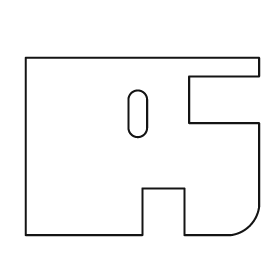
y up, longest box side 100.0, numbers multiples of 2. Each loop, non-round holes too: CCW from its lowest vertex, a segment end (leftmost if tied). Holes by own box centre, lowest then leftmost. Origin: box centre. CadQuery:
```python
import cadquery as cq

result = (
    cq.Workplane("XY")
    .moveTo(-50.0, -38.0)
    .lineTo(0.0, -38.0)
    .lineTo(0.0, -18.0)
    .lineTo(18.0, -18.0)
    .lineTo(18.0, -38.0)
    .lineTo(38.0, -38.0)
    .threePointArc((46.0, -34.0), (50.0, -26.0))
    .lineTo(50.0, 10.0)
    .lineTo(20.0, 10.0)
    .lineTo(20.0, 30.0)
    .lineTo(50.0, 30.0)
    .lineTo(50.0, 38.0)
    .lineTo(-50.0, 38.0)
    .close()
    .moveTo(-6.0, 8.0)
    .threePointArc((-2.0, 4.0), (2.0, 8.0))
    .lineTo(2.0, 20.0)
    .threePointArc((-2.0, 24.0), (-6.0, 20.0))
    .close()
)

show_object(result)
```